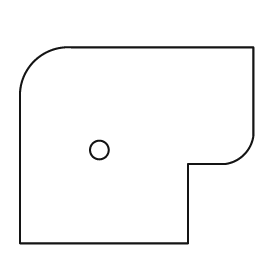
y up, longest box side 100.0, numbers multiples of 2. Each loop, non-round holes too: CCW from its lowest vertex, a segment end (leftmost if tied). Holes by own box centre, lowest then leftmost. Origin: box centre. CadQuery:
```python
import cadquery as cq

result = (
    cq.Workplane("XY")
    .moveTo(-50.0, -42.0)
    .lineTo(22.0, -42.0)
    .lineTo(22.0, -8.0)
    .lineTo(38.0, -8.0)
    .threePointArc((46.0, -4.0), (50.0, 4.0))
    .lineTo(50.0, 42.0)
    .lineTo(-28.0, 42.0)
    .threePointArc((-44.0, 36.0), (-50.0, 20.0))
    .close()
    .moveTo(-16.0, -2.0)
    .circle(4.0)
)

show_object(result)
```